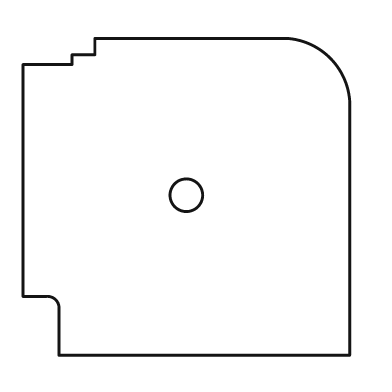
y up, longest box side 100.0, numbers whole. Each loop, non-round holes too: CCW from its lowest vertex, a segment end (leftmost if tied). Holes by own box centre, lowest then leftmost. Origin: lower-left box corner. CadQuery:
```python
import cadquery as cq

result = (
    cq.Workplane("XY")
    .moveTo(11.0, 0.0)
    .lineTo(100.0, 0.0)
    .lineTo(100.0, 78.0)
    .threePointArc((94.0, 91.0), (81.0, 97.0))
    .lineTo(22.0, 97.0)
    .lineTo(22.0, 92.0)
    .lineTo(15.0, 92.0)
    .lineTo(15.0, 89.0)
    .lineTo(0.0, 89.0)
    .lineTo(0.0, 18.0)
    .lineTo(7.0, 18.0)
    .threePointArc((10.0, 17.0), (11.0, 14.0))
    .close()
    .moveTo(50.0, 49.0)
    .circle(5.0)
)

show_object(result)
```